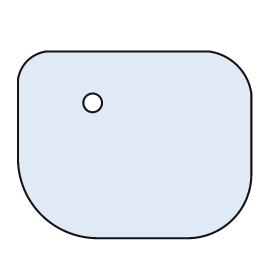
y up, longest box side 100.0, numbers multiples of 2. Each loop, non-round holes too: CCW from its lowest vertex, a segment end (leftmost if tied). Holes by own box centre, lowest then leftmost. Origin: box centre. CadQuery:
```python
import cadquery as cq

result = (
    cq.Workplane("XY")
    .moveTo(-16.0, -40.0)
    .lineTo(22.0, -40.0)
    .threePointArc((42.0, -32.0), (50.0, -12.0))
    .lineTo(50.0, 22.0)
    .threePointArc((44.0, 34.0), (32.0, 40.0))
    .lineTo(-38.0, 40.0)
    .threePointArc((-46.0, 36.0), (-50.0, 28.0))
    .lineTo(-50.0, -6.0)
    .threePointArc((-40.0, -30.0), (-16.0, -40.0))
    .close()
    .moveTo(-18.0, 18.0)
    .circle(4.0)
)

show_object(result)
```